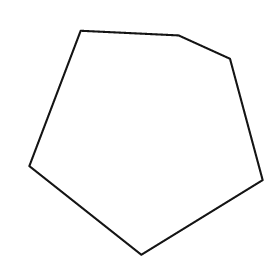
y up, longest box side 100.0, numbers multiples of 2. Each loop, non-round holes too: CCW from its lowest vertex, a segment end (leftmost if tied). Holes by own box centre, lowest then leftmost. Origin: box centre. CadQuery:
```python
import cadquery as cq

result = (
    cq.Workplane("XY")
    .moveTo(-2.0, -48.0)
    .lineTo(50.0, -16.0)
    .lineTo(36.0, 36.0)
    .lineTo(14.0, 46.0)
    .lineTo(-28.0, 48.0)
    .lineTo(-50.0, -10.0)
    .close()
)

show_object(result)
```